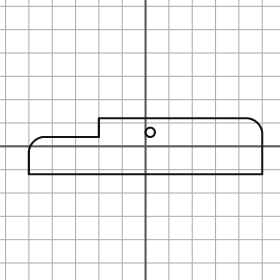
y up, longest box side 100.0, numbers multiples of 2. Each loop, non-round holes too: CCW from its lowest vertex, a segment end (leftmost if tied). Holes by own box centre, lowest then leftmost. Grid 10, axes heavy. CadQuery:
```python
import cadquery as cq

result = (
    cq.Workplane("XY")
    .moveTo(-50.0, -12.0)
    .lineTo(50.0, -12.0)
    .lineTo(50.0, 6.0)
    .threePointArc((48.0, 10.0), (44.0, 12.0))
    .lineTo(-20.0, 12.0)
    .lineTo(-20.0, 4.0)
    .lineTo(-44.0, 4.0)
    .threePointArc((-48.0, 2.0), (-50.0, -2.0))
    .close()
    .moveTo(2.0, 6.0)
    .circle(2.0)
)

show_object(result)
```